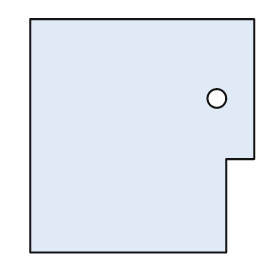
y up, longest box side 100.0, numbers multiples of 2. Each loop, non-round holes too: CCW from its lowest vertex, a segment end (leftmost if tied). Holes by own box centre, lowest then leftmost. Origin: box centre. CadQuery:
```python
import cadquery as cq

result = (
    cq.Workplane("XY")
    .moveTo(-48.0, -50.0)
    .lineTo(36.0, -50.0)
    .lineTo(36.0, -10.0)
    .lineTo(48.0, -10.0)
    .lineTo(48.0, 50.0)
    .lineTo(-48.0, 50.0)
    .close()
    .moveTo(32.0, 16.0)
    .circle(4.0)
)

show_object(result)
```